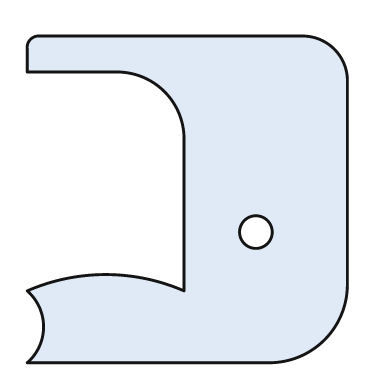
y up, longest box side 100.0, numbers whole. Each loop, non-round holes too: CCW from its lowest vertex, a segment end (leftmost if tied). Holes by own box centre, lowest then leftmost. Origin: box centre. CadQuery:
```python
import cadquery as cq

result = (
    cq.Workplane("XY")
    .moveTo(-49.0, -50.0)
    .lineTo(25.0, -50.0)
    .threePointArc((42.0, -43.0), (49.0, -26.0))
    .lineTo(49.0, 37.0)
    .threePointArc((45.0, 46.0), (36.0, 50.0))
    .lineTo(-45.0, 50.0)
    .threePointArc((-48.0, 49.0), (-49.0, 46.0))
    .lineTo(-49.0, 39.0)
    .lineTo(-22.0, 39.0)
    .threePointArc((-7.0, 33.0), (-1.0, 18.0))
    .lineTo(-1.0, -28.0)
    .threePointArc((-25.0, -23.0), (-49.0, -28.0))
    .threePointArc((-44.0, -39.0), (-49.0, -50.0))
    .close()
    .moveTo(21.0, -10.0)
    .circle(5.0)
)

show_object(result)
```